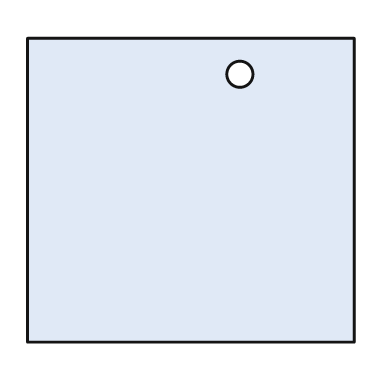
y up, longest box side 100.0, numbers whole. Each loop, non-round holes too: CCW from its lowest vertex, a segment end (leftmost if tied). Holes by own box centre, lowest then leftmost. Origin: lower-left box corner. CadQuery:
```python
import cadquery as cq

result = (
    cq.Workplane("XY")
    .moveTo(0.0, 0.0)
    .lineTo(100.0, 0.0)
    .lineTo(100.0, 93.0)
    .lineTo(0.0, 93.0)
    .close()
    .moveTo(65.0, 82.0)
    .circle(4.0)
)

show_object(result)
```